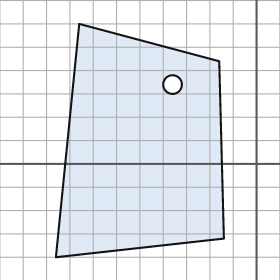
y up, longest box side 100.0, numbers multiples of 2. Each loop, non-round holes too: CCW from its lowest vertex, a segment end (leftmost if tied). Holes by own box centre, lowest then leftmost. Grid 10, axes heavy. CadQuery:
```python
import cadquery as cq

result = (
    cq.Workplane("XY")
    .moveTo(-86.0, -40.0)
    .lineTo(-14.0, -32.0)
    .lineTo(-16.0, 44.0)
    .lineTo(-76.0, 60.0)
    .close()
    .moveTo(-36.0, 34.0)
    .circle(4.0)
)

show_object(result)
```